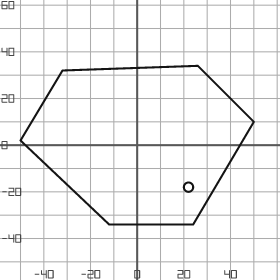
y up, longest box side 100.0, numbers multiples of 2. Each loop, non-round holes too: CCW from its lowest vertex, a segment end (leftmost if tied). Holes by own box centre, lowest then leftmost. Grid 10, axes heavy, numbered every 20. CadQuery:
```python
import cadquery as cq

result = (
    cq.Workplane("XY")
    .moveTo(-12.0, -34.0)
    .lineTo(24.0, -34.0)
    .lineTo(50.0, 10.0)
    .lineTo(26.0, 34.0)
    .lineTo(-32.0, 32.0)
    .lineTo(-50.0, 2.0)
    .close()
    .moveTo(22.0, -18.0)
    .circle(2.0)
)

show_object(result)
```